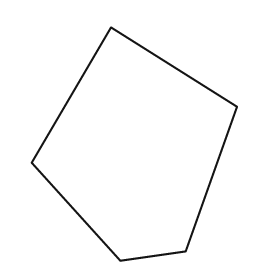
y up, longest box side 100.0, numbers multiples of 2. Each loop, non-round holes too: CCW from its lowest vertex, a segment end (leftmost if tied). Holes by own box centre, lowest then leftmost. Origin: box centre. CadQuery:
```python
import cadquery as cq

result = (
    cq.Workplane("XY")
    .moveTo(-6.0, -50.0)
    .lineTo(22.0, -46.0)
    .lineTo(44.0, 16.0)
    .lineTo(-10.0, 50.0)
    .lineTo(-44.0, -8.0)
    .close()
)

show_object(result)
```